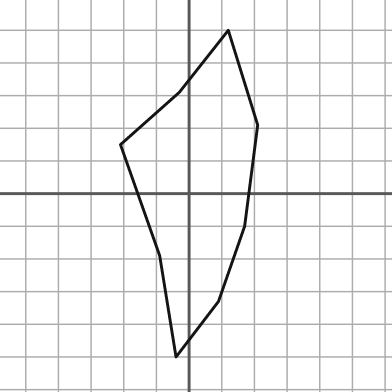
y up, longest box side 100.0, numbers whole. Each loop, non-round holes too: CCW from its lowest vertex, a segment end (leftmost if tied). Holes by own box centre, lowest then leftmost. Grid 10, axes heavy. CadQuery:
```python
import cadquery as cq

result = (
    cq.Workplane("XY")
    .moveTo(-4.0, -50.0)
    .lineTo(9.0, -33.0)
    .lineTo(17.0, -10.0)
    .lineTo(21.0, 21.0)
    .lineTo(12.0, 50.0)
    .lineTo(-3.0, 31.0)
    .lineTo(-21.0, 15.0)
    .lineTo(-9.0, -19.0)
    .close()
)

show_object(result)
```